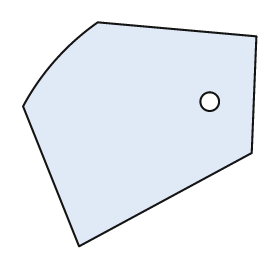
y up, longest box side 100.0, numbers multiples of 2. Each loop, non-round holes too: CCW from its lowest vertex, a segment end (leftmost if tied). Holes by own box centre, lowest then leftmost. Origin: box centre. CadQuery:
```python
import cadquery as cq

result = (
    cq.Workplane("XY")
    .moveTo(-26.0, -48.0)
    .lineTo(48.0, -8.0)
    .lineTo(50.0, 42.0)
    .lineTo(-18.0, 48.0)
    .threePointArc((-36.0, 32.0), (-50.0, 12.0))
    .close()
    .moveTo(30.0, 14.0)
    .circle(4.0)
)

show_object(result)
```